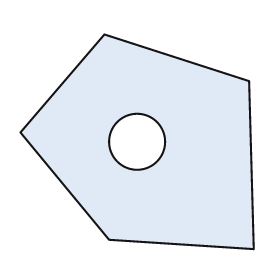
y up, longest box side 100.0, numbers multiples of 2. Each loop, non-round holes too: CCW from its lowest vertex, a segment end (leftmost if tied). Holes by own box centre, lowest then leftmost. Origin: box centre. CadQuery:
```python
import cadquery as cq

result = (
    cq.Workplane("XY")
    .moveTo(50.0, -46.0)
    .lineTo(48.0, 26.0)
    .lineTo(-14.0, 46.0)
    .lineTo(-50.0, 4.0)
    .lineTo(-12.0, -42.0)
    .close()
    .moveTo(0.0, 0.0)
    .circle(12.0)
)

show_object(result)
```